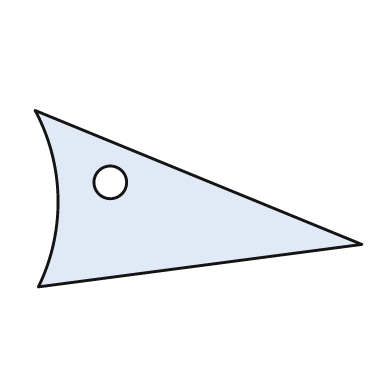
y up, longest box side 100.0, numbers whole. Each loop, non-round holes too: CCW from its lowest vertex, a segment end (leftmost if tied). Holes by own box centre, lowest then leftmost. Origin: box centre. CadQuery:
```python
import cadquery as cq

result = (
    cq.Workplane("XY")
    .moveTo(-49.0, -27.0)
    .lineTo(50.0, -14.0)
    .lineTo(-50.0, 27.0)
    .threePointArc((-43.0, 0.0), (-49.0, -27.0))
    .close()
    .moveTo(-27.0, 5.0)
    .circle(5.0)
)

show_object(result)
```